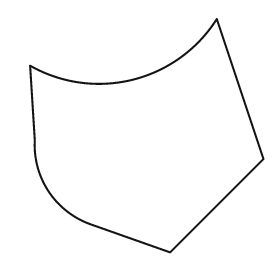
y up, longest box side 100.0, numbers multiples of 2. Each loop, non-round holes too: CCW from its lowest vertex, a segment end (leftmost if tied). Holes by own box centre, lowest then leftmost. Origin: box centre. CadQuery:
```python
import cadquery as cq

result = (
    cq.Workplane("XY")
    .moveTo(10.0, -50.0)
    .lineTo(50.0, -10.0)
    .lineTo(30.0, 50.0)
    .threePointArc((-6.0, 24.0), (-50.0, 30.0))
    .lineTo(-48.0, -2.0)
    .threePointArc((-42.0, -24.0), (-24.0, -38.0))
    .close()
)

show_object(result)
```